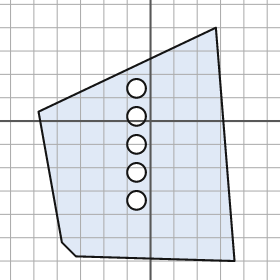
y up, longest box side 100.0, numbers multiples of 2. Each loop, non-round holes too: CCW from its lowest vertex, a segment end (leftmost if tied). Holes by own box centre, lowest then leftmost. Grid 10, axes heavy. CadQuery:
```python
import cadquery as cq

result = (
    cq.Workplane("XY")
    .moveTo(36.0, -60.0)
    .lineTo(28.0, 40.0)
    .lineTo(-48.0, 4.0)
    .lineTo(-38.0, -52.0)
    .lineTo(-32.0, -58.0)
    .close()
    .moveTo(-6.0, -34.0)
    .circle(4.0)
    .moveTo(-6.0, -22.0)
    .circle(4.0)
    .moveTo(-6.0, -10.0)
    .circle(4.0)
    .moveTo(-6.0, 2.0)
    .circle(4.0)
    .moveTo(-6.0, 14.0)
    .circle(4.0)
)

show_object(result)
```